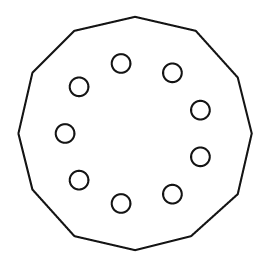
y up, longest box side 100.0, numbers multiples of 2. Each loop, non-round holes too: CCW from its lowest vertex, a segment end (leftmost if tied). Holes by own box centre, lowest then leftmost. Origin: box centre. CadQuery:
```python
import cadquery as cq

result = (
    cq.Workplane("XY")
    .moveTo(0.0, -50.0)
    .lineTo(24.0, -44.0)
    .lineTo(44.0, -26.0)
    .lineTo(50.0, 0.0)
    .lineTo(44.0, 24.0)
    .lineTo(26.0, 44.0)
    .lineTo(0.0, 50.0)
    .lineTo(-26.0, 44.0)
    .lineTo(-44.0, 26.0)
    .lineTo(-50.0, 0.0)
    .lineTo(-44.0, -24.0)
    .lineTo(-26.0, -44.0)
    .close()
    .moveTo(-6.0, -30.0)
    .circle(4.0)
    .moveTo(16.0, -26.0)
    .circle(4.0)
    .moveTo(-24.0, -20.0)
    .circle(4.0)
    .moveTo(28.0, -10.0)
    .circle(4.0)
    .moveTo(-30.0, 0.0)
    .circle(4.0)
    .moveTo(28.0, 10.0)
    .circle(4.0)
    .moveTo(-24.0, 20.0)
    .circle(4.0)
    .moveTo(16.0, 26.0)
    .circle(4.0)
    .moveTo(-6.0, 30.0)
    .circle(4.0)
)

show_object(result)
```